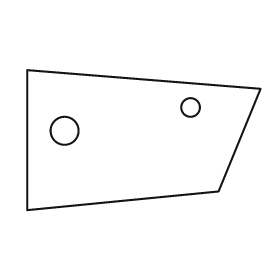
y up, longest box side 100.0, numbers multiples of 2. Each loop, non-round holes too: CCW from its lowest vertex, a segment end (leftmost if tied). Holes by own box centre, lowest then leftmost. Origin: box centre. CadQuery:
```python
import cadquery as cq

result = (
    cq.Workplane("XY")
    .moveTo(-50.0, -30.0)
    .lineTo(32.0, -22.0)
    .lineTo(50.0, 22.0)
    .lineTo(-50.0, 30.0)
    .close()
    .moveTo(-34.0, 4.0)
    .circle(6.0)
    .moveTo(20.0, 14.0)
    .circle(4.0)
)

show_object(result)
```